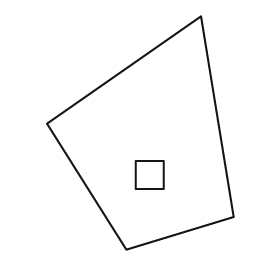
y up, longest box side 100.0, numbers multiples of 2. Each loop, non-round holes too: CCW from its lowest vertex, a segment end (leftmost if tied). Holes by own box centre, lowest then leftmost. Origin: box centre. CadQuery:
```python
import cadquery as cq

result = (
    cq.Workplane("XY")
    .moveTo(-6.0, -50.0)
    .lineTo(40.0, -36.0)
    .lineTo(26.0, 50.0)
    .lineTo(-40.0, 4.0)
    .close()
    .moveTo(-2.0, -24.0)
    .lineTo(10.0, -24.0)
    .lineTo(10.0, -12.0)
    .lineTo(-2.0, -12.0)
    .close()
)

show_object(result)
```